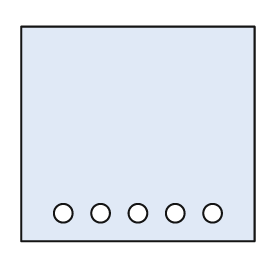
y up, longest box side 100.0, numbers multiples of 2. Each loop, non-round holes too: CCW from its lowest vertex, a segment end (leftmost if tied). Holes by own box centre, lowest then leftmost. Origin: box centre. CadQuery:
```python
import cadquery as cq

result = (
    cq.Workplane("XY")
    .moveTo(-50.0, -46.0)
    .lineTo(50.0, -46.0)
    .lineTo(50.0, 46.0)
    .lineTo(-50.0, 46.0)
    .close()
    .moveTo(-32.0, -34.0)
    .circle(4.0)
    .moveTo(-16.0, -34.0)
    .circle(4.0)
    .moveTo(0.0, -34.0)
    .circle(4.0)
    .moveTo(16.0, -34.0)
    .circle(4.0)
    .moveTo(32.0, -34.0)
    .circle(4.0)
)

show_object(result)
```